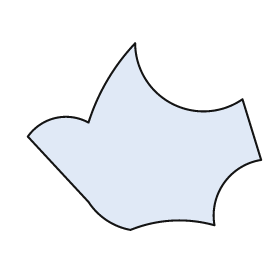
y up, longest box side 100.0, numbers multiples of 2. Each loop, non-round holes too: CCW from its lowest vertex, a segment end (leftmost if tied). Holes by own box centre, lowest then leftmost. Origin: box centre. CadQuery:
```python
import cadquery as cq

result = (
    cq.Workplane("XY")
    .moveTo(-6.0, -40.0)
    .threePointArc((12.0, -36.0), (30.0, -38.0))
    .threePointArc((34.0, -20.0), (50.0, -10.0))
    .lineTo(42.0, 16.0)
    .threePointArc((12.0, 14.0), (-4.0, 40.0))
    .threePointArc((-16.0, 24.0), (-24.0, 6.0))
    .threePointArc((-38.0, 8.0), (-50.0, 0.0))
    .lineTo(-24.0, -28.0)
    .threePointArc((-16.0, -36.0), (-6.0, -40.0))
    .close()
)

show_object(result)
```